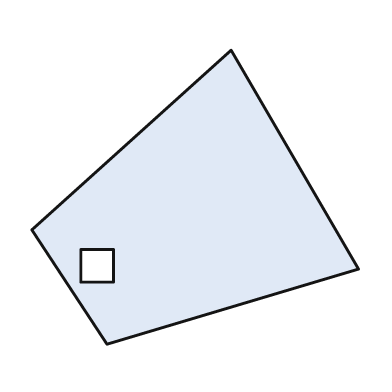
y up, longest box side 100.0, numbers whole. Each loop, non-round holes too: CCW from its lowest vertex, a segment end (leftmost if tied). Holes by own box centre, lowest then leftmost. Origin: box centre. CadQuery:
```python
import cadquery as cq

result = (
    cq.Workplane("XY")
    .moveTo(-27.0, -45.0)
    .lineTo(50.0, -22.0)
    .lineTo(11.0, 45.0)
    .lineTo(-50.0, -10.0)
    .close()
    .moveTo(-35.0, -26.0)
    .lineTo(-25.0, -26.0)
    .lineTo(-25.0, -16.0)
    .lineTo(-35.0, -16.0)
    .close()
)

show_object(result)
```